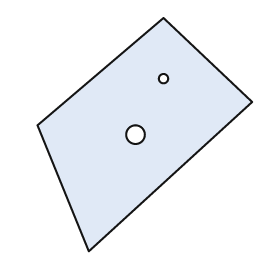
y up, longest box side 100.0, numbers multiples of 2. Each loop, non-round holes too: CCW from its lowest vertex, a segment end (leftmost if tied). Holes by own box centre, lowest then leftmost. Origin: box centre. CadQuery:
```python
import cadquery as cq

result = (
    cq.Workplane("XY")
    .moveTo(-24.0, -50.0)
    .lineTo(46.0, 14.0)
    .lineTo(8.0, 50.0)
    .lineTo(-46.0, 4.0)
    .close()
    .moveTo(-4.0, 0.0)
    .circle(4.0)
    .moveTo(8.0, 24.0)
    .circle(2.0)
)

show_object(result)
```